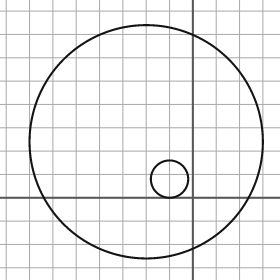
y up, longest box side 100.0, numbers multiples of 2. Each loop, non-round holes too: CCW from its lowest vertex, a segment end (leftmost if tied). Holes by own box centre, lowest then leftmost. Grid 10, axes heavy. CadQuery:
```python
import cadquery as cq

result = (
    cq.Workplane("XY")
    .moveTo(-20.0, 24.0)
    .circle(50.0)
    .moveTo(-10.0, 8.0)
    .circle(8.0)
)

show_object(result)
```